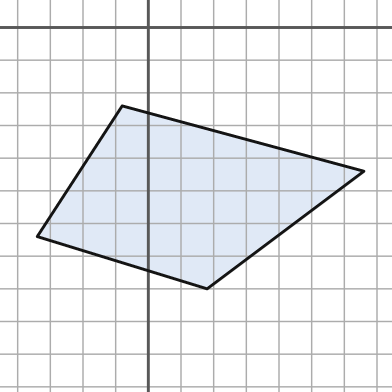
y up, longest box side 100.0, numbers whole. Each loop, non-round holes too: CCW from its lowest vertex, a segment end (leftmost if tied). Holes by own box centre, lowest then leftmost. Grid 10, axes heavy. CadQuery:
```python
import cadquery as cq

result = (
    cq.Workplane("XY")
    .moveTo(18.0, -80.0)
    .lineTo(66.0, -44.0)
    .lineTo(-8.0, -24.0)
    .lineTo(-34.0, -64.0)
    .close()
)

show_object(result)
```